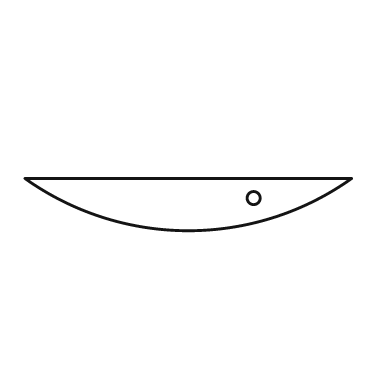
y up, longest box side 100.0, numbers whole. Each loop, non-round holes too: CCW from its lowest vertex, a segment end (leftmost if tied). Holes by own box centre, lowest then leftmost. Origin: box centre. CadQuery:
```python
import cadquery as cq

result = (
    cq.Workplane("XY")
    .moveTo(-50.0, 8.0)
    .threePointArc((0.0, -8.0), (50.0, 8.0))
    .close()
    .moveTo(20.0, 2.0)
    .circle(2.0)
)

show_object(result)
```